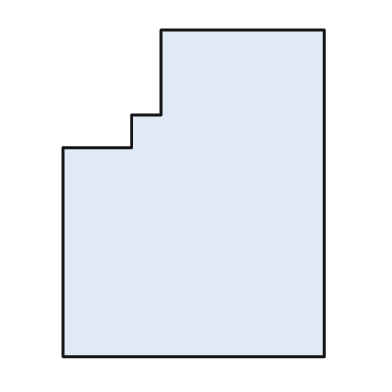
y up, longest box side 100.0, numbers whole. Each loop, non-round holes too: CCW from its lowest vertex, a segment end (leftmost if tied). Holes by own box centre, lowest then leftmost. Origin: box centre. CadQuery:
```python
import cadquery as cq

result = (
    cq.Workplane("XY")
    .moveTo(-40.0, -50.0)
    .lineTo(40.0, -50.0)
    .lineTo(40.0, 50.0)
    .lineTo(-10.0, 50.0)
    .lineTo(-10.0, 24.0)
    .lineTo(-19.0, 24.0)
    .lineTo(-19.0, 14.0)
    .lineTo(-40.0, 14.0)
    .close()
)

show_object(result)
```